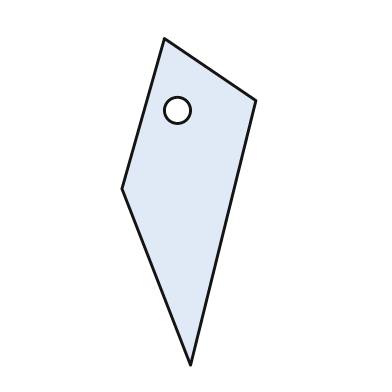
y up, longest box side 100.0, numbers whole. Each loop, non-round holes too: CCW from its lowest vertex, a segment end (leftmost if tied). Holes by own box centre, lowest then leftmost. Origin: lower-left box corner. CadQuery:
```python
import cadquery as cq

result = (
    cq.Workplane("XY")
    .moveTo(21.0, 0.0)
    .lineTo(41.0, 81.0)
    .lineTo(13.0, 100.0)
    .lineTo(0.0, 54.0)
    .close()
    .moveTo(17.0, 78.0)
    .circle(4.0)
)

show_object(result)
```